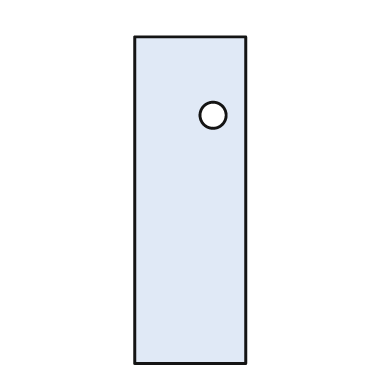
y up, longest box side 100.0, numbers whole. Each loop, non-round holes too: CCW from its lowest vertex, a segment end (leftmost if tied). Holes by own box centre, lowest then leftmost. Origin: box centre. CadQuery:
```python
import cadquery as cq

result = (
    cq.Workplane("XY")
    .moveTo(-17.0, -50.0)
    .lineTo(17.0, -50.0)
    .lineTo(17.0, 50.0)
    .lineTo(-17.0, 50.0)
    .close()
    .moveTo(7.0, 26.0)
    .circle(4.0)
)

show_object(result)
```